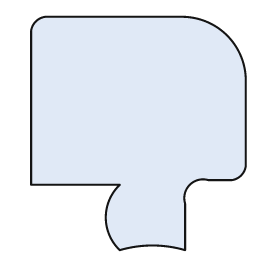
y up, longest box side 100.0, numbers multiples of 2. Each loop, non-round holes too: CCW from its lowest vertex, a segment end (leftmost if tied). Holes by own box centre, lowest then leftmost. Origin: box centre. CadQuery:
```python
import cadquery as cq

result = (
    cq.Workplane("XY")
    .moveTo(-8.0, -50.0)
    .threePointArc((6.0, -48.0), (20.0, -50.0))
    .lineTo(20.0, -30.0)
    .threePointArc((22.0, -22.0), (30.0, -20.0))
    .lineTo(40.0, -20.0)
    .threePointArc((44.0, -18.0), (46.0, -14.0))
    .lineTo(46.0, 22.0)
    .threePointArc((38.0, 42.0), (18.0, 50.0))
    .lineTo(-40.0, 50.0)
    .threePointArc((-44.0, 48.0), (-46.0, 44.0))
    .lineTo(-46.0, -22.0)
    .lineTo(-8.0, -22.0)
    .threePointArc((-14.0, -36.0), (-8.0, -50.0))
    .close()
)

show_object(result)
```